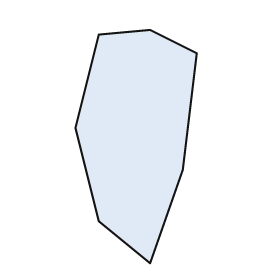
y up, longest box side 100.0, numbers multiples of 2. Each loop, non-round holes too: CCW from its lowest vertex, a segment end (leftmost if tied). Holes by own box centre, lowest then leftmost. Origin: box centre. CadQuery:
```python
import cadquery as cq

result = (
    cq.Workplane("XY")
    .moveTo(6.0, -50.0)
    .lineTo(20.0, -10.0)
    .lineTo(26.0, 40.0)
    .lineTo(6.0, 50.0)
    .lineTo(-16.0, 48.0)
    .lineTo(-26.0, 8.0)
    .lineTo(-16.0, -32.0)
    .close()
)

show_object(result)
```